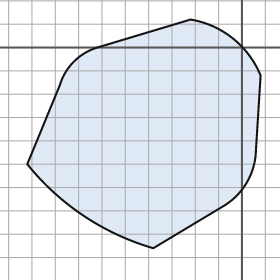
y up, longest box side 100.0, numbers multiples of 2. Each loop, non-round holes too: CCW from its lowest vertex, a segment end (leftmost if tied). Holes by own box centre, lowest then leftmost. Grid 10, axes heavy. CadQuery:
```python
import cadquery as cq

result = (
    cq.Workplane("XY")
    .moveTo(-38.0, -86.0)
    .lineTo(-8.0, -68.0)
    .threePointArc((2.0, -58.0), (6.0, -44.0))
    .lineTo(8.0, -12.0)
    .threePointArc((-4.0, 4.0), (-22.0, 12.0))
    .lineTo(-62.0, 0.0)
    .threePointArc((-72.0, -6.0), (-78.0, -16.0))
    .lineTo(-92.0, -50.0)
    .threePointArc((-68.0, -72.0), (-38.0, -86.0))
    .close()
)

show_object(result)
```